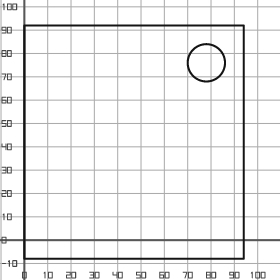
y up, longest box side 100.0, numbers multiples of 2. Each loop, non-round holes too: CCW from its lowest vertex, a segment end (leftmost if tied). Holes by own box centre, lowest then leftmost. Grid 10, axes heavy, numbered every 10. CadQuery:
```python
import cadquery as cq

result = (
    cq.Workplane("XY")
    .moveTo(0.0, -8.0)
    .lineTo(94.0, -8.0)
    .lineTo(94.0, 92.0)
    .lineTo(0.0, 92.0)
    .close()
    .moveTo(78.0, 76.0)
    .circle(8.0)
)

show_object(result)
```